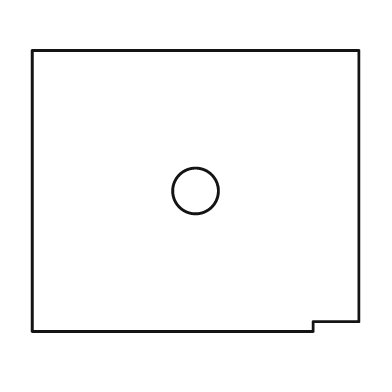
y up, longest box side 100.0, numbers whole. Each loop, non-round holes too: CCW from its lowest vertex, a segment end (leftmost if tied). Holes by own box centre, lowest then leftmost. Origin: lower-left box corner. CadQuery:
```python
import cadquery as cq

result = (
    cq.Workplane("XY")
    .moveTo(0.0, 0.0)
    .lineTo(86.0, 0.0)
    .lineTo(86.0, 3.0)
    .lineTo(100.0, 3.0)
    .lineTo(100.0, 86.0)
    .lineTo(0.0, 86.0)
    .close()
    .moveTo(50.0, 43.0)
    .circle(7.0)
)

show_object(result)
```